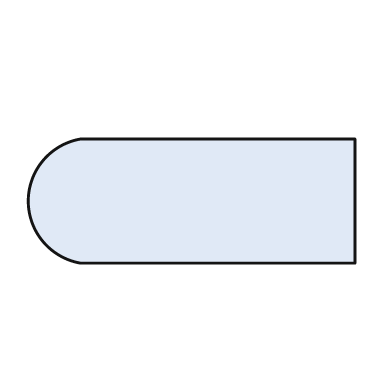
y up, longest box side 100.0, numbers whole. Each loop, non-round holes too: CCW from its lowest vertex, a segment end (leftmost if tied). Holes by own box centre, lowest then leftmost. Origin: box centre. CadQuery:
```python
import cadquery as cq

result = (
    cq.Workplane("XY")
    .moveTo(-34.0, -19.0)
    .lineTo(50.0, -19.0)
    .lineTo(50.0, 19.0)
    .lineTo(-34.0, 19.0)
    .threePointArc((-50.0, 0.0), (-34.0, -19.0))
    .close()
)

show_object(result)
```